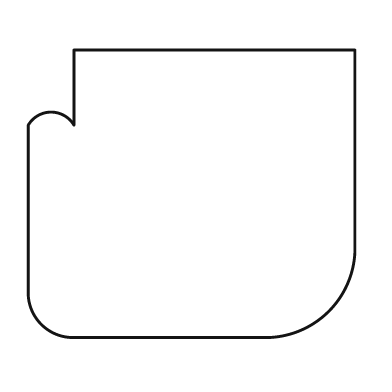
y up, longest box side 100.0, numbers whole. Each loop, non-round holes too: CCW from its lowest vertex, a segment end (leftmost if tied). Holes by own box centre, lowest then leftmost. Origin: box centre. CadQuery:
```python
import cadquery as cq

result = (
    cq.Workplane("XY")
    .moveTo(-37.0, -44.0)
    .lineTo(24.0, -44.0)
    .threePointArc((42.0, -36.0), (50.0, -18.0))
    .lineTo(50.0, 44.0)
    .lineTo(-36.0, 44.0)
    .lineTo(-36.0, 21.0)
    .threePointArc((-43.0, 25.0), (-50.0, 21.0))
    .lineTo(-50.0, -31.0)
    .threePointArc((-46.0, -40.0), (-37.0, -44.0))
    .close()
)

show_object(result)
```